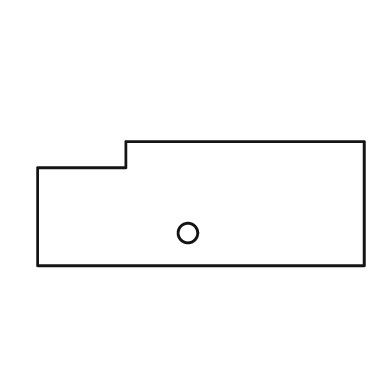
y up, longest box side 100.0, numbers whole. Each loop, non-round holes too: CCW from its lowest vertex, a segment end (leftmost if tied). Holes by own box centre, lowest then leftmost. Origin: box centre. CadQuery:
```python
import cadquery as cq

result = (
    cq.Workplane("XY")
    .moveTo(-50.0, -19.0)
    .lineTo(50.0, -19.0)
    .lineTo(50.0, 19.0)
    .lineTo(-23.0, 19.0)
    .lineTo(-23.0, 11.0)
    .lineTo(-50.0, 11.0)
    .close()
    .moveTo(-4.0, -9.0)
    .circle(3.0)
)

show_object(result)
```